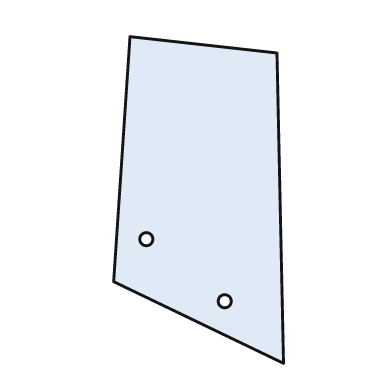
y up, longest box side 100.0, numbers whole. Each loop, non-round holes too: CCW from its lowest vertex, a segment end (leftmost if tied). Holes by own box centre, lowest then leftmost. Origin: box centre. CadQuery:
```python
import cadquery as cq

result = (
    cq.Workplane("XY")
    .moveTo(26.0, -50.0)
    .lineTo(24.0, 45.0)
    .lineTo(-21.0, 50.0)
    .lineTo(-26.0, -25.0)
    .close()
    .moveTo(8.0, -31.0)
    .circle(2.0)
    .moveTo(-16.0, -12.0)
    .circle(2.0)
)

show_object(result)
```